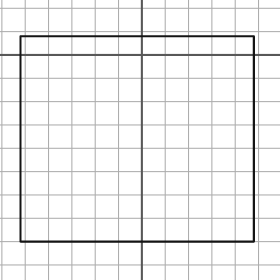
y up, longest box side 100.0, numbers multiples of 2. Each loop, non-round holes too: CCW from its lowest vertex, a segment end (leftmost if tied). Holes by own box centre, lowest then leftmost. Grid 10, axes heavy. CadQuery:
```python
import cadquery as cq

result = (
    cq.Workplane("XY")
    .moveTo(-52.0, -80.0)
    .lineTo(48.0, -80.0)
    .lineTo(48.0, 8.0)
    .lineTo(-52.0, 8.0)
    .close()
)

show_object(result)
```